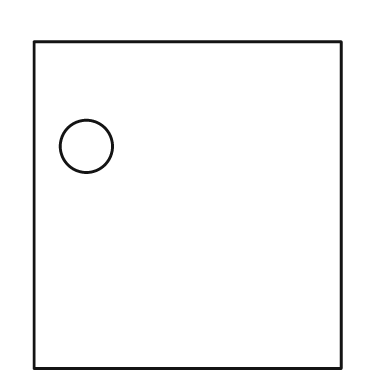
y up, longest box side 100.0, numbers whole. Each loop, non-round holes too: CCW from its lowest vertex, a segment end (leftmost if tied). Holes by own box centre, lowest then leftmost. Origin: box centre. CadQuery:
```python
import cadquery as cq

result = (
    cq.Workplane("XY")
    .moveTo(-47.0, -50.0)
    .lineTo(47.0, -50.0)
    .lineTo(47.0, 50.0)
    .lineTo(-47.0, 50.0)
    .close()
    .moveTo(-31.0, 18.0)
    .circle(8.0)
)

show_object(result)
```